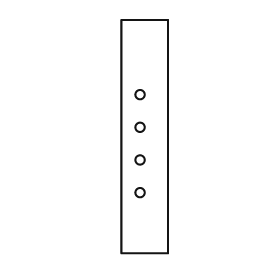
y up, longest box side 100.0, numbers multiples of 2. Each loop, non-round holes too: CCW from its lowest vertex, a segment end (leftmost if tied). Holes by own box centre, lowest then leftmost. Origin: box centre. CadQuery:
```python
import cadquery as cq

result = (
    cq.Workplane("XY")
    .moveTo(-10.0, -50.0)
    .lineTo(10.0, -50.0)
    .lineTo(10.0, 50.0)
    .lineTo(-10.0, 50.0)
    .close()
    .moveTo(-2.0, -24.0)
    .circle(2.0)
    .moveTo(-2.0, -10.0)
    .circle(2.0)
    .moveTo(-2.0, 4.0)
    .circle(2.0)
    .moveTo(-2.0, 18.0)
    .circle(2.0)
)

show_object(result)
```